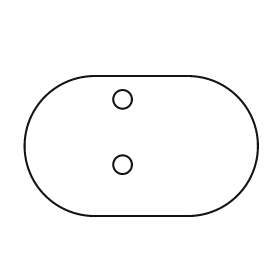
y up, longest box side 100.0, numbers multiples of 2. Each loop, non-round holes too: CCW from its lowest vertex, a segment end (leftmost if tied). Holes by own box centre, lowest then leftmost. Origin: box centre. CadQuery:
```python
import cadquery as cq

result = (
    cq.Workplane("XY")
    .moveTo(-20.0, -30.0)
    .lineTo(20.0, -30.0)
    .threePointArc((50.0, 0.0), (20.0, 30.0))
    .lineTo(-20.0, 30.0)
    .threePointArc((-50.0, 0.0), (-20.0, -30.0))
    .close()
    .moveTo(-8.0, -8.0)
    .circle(4.0)
    .moveTo(-8.0, 20.0)
    .circle(4.0)
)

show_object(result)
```